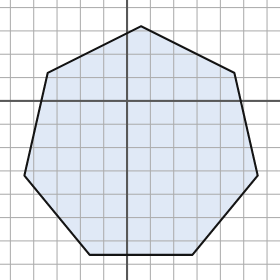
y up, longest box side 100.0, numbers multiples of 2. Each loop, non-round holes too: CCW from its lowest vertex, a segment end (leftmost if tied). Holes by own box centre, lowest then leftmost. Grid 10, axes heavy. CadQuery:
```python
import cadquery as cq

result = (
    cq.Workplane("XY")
    .moveTo(-16.0, -66.0)
    .lineTo(28.0, -66.0)
    .lineTo(56.0, -32.0)
    .lineTo(46.0, 12.0)
    .lineTo(6.0, 32.0)
    .lineTo(-34.0, 12.0)
    .lineTo(-44.0, -32.0)
    .close()
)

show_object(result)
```